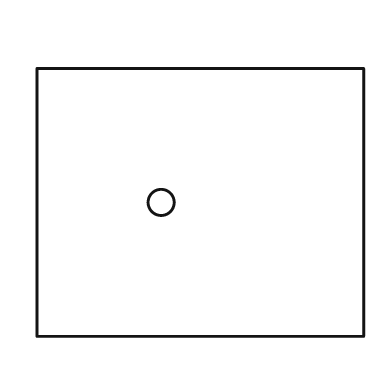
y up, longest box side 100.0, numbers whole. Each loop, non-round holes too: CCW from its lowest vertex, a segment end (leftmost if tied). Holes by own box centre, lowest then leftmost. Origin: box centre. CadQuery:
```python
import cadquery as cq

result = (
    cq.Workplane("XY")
    .moveTo(-50.0, -41.0)
    .lineTo(50.0, -41.0)
    .lineTo(50.0, 41.0)
    .lineTo(-50.0, 41.0)
    .close()
    .moveTo(-12.0, 0.0)
    .circle(4.0)
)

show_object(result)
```